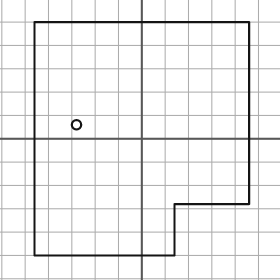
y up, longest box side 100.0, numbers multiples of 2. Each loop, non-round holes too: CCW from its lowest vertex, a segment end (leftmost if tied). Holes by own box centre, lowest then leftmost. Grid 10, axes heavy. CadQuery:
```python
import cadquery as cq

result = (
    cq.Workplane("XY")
    .moveTo(-46.0, -50.0)
    .lineTo(14.0, -50.0)
    .lineTo(14.0, -28.0)
    .lineTo(46.0, -28.0)
    .lineTo(46.0, 50.0)
    .lineTo(-46.0, 50.0)
    .close()
    .moveTo(-28.0, 6.0)
    .circle(2.0)
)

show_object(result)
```